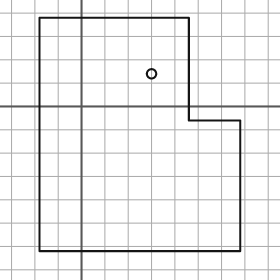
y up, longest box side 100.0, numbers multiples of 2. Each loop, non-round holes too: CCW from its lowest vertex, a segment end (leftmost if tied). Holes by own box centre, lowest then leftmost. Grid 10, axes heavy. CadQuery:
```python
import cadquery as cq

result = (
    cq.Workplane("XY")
    .moveTo(-18.0, -62.0)
    .lineTo(68.0, -62.0)
    .lineTo(68.0, -6.0)
    .lineTo(46.0, -6.0)
    .lineTo(46.0, 38.0)
    .lineTo(-18.0, 38.0)
    .close()
    .moveTo(30.0, 14.0)
    .circle(2.0)
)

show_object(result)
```